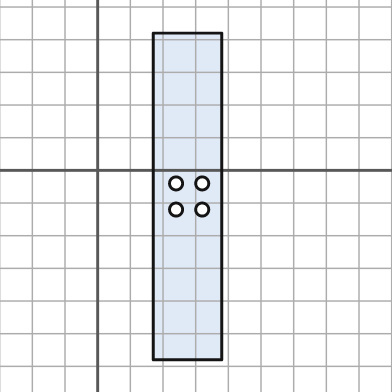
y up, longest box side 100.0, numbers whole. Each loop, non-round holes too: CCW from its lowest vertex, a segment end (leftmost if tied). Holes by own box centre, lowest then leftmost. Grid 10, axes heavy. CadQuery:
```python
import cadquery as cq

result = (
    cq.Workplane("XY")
    .moveTo(17.0, -58.0)
    .lineTo(38.0, -58.0)
    .lineTo(38.0, 42.0)
    .lineTo(17.0, 42.0)
    .close()
    .moveTo(24.0, -12.0)
    .circle(2.0)
    .moveTo(32.0, -12.0)
    .circle(2.0)
    .moveTo(24.0, -4.0)
    .circle(2.0)
    .moveTo(32.0, -4.0)
    .circle(2.0)
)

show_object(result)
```